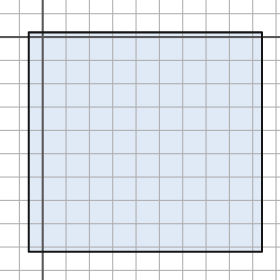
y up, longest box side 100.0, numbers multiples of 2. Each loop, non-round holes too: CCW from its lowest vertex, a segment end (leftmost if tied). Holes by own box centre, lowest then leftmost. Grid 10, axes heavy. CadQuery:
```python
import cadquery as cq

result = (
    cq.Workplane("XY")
    .moveTo(-6.0, -92.0)
    .lineTo(94.0, -92.0)
    .lineTo(94.0, 2.0)
    .lineTo(-6.0, 2.0)
    .close()
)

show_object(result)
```